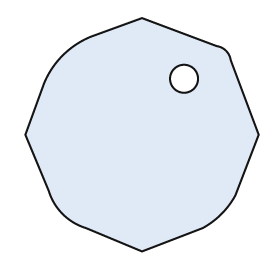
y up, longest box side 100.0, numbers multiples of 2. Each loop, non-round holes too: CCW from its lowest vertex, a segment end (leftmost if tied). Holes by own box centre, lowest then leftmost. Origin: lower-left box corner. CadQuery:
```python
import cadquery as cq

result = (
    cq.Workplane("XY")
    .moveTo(50.0, 0.0)
    .lineTo(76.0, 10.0)
    .threePointArc((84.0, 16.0), (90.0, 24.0))
    .lineTo(100.0, 50.0)
    .lineTo(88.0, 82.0)
    .threePointArc((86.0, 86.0), (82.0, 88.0))
    .lineTo(50.0, 100.0)
    .lineTo(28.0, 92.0)
    .threePointArc((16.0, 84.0), (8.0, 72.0))
    .lineTo(0.0, 50.0)
    .lineTo(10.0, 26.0)
    .threePointArc((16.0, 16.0), (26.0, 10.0))
    .close()
    .moveTo(68.0, 74.0)
    .circle(6.0)
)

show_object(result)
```